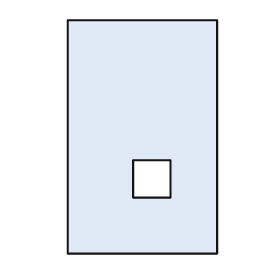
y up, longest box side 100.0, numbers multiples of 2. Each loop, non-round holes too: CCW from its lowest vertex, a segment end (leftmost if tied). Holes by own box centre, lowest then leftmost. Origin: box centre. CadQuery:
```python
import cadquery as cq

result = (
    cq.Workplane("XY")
    .moveTo(-32.0, -50.0)
    .lineTo(32.0, -50.0)
    .lineTo(32.0, 50.0)
    .lineTo(-32.0, 50.0)
    .close()
    .moveTo(-4.0, -26.0)
    .lineTo(12.0, -26.0)
    .lineTo(12.0, -10.0)
    .lineTo(-4.0, -10.0)
    .close()
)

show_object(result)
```